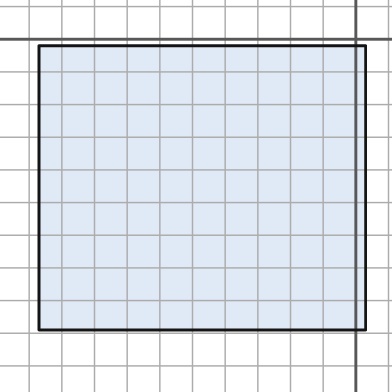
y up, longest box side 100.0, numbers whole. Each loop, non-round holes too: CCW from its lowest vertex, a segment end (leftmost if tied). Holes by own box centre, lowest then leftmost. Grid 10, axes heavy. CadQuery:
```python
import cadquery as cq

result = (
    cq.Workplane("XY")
    .moveTo(-97.0, -89.0)
    .lineTo(3.0, -89.0)
    .lineTo(3.0, -2.0)
    .lineTo(-97.0, -2.0)
    .close()
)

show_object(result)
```